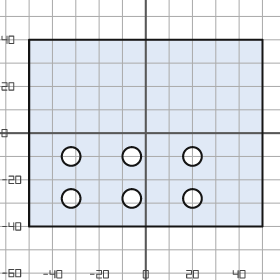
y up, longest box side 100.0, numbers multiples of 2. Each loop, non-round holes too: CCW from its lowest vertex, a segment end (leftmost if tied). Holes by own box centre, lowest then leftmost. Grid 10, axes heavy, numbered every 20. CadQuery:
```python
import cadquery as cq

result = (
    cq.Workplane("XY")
    .moveTo(-50.0, -40.0)
    .lineTo(50.0, -40.0)
    .lineTo(50.0, 40.0)
    .lineTo(-50.0, 40.0)
    .close()
    .moveTo(-32.0, -28.0)
    .circle(4.0)
    .moveTo(-6.0, -28.0)
    .circle(4.0)
    .moveTo(20.0, -28.0)
    .circle(4.0)
    .moveTo(-32.0, -10.0)
    .circle(4.0)
    .moveTo(-6.0, -10.0)
    .circle(4.0)
    .moveTo(20.0, -10.0)
    .circle(4.0)
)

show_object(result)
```